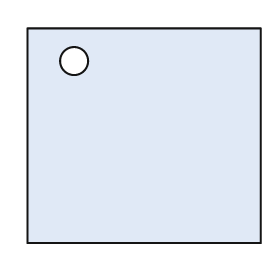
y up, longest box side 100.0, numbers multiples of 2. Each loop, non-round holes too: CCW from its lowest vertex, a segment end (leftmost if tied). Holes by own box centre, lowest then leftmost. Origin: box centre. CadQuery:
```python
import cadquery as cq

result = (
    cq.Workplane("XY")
    .moveTo(-50.0, -46.0)
    .lineTo(50.0, -46.0)
    .lineTo(50.0, 46.0)
    .lineTo(-50.0, 46.0)
    .close()
    .moveTo(-30.0, 32.0)
    .circle(6.0)
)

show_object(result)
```